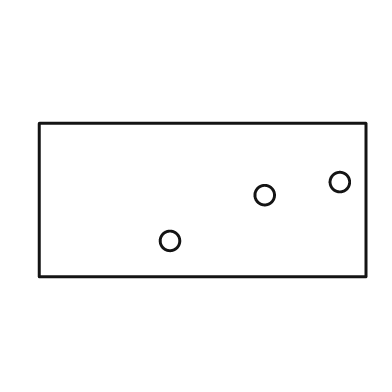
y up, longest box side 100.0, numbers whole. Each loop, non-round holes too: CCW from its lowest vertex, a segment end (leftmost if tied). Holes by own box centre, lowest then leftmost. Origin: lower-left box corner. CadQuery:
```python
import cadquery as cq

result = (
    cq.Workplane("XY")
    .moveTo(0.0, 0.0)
    .lineTo(100.0, 0.0)
    .lineTo(100.0, 47.0)
    .lineTo(0.0, 47.0)
    .close()
    .moveTo(40.0, 11.0)
    .circle(3.0)
    .moveTo(69.0, 25.0)
    .circle(3.0)
    .moveTo(92.0, 29.0)
    .circle(3.0)
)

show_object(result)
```